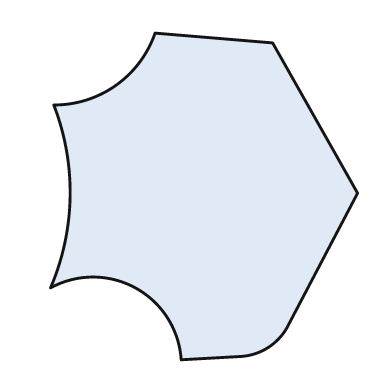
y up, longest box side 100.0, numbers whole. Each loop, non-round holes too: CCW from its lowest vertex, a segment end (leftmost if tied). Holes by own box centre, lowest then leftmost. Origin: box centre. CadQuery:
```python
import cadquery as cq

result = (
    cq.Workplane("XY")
    .moveTo(-7.0, -50.0)
    .lineTo(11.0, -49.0)
    .threePointArc((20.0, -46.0), (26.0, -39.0))
    .lineTo(47.0, 1.0)
    .lineTo(21.0, 47.0)
    .lineTo(-15.0, 50.0)
    .threePointArc((-27.0, 34.0), (-46.0, 28.0))
    .threePointArc((-41.0, 0.0), (-47.0, -28.0))
    .threePointArc((-21.0, -28.0), (-7.0, -50.0))
    .close()
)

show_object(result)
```